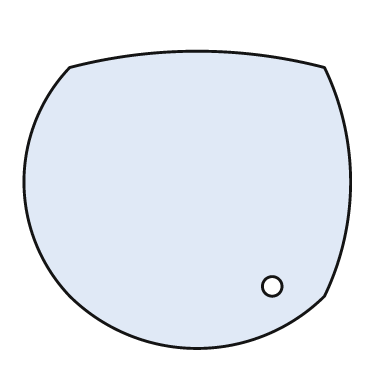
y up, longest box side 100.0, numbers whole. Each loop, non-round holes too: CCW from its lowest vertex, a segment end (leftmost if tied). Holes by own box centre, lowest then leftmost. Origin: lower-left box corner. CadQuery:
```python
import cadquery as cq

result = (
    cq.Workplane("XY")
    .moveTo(14.0, 16.0)
    .threePointArc((53.0, 0.0), (92.0, 16.0))
    .threePointArc((100.0, 51.0), (92.0, 86.0))
    .threePointArc((53.0, 91.0), (14.0, 86.0))
    .threePointArc((0.0, 51.0), (14.0, 16.0))
    .close()
    .moveTo(76.0, 19.0)
    .circle(3.0)
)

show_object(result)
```